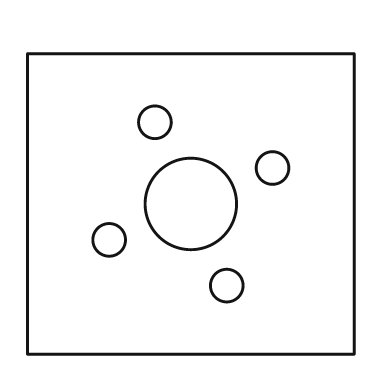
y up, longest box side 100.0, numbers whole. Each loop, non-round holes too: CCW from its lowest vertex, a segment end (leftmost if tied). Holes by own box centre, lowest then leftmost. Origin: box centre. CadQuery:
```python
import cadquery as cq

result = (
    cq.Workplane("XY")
    .moveTo(-50.0, -46.0)
    .lineTo(50.0, -46.0)
    .lineTo(50.0, 46.0)
    .lineTo(-50.0, 46.0)
    .close()
    .moveTo(11.0, -25.0)
    .circle(5.0)
    .moveTo(-25.0, -11.0)
    .circle(5.0)
    .moveTo(0.0, 0.0)
    .circle(14.0)
    .moveTo(25.0, 11.0)
    .circle(5.0)
    .moveTo(-11.0, 25.0)
    .circle(5.0)
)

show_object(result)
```